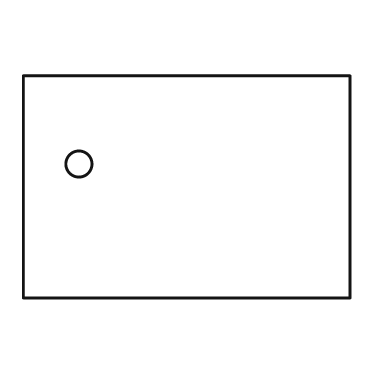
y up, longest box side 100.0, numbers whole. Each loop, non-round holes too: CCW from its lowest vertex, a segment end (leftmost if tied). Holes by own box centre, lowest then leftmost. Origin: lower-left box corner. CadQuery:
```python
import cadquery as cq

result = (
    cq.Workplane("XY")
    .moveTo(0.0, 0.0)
    .lineTo(100.0, 0.0)
    .lineTo(100.0, 68.0)
    .lineTo(0.0, 68.0)
    .close()
    .moveTo(17.0, 41.0)
    .circle(4.0)
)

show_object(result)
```